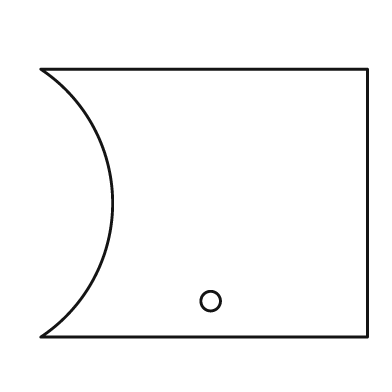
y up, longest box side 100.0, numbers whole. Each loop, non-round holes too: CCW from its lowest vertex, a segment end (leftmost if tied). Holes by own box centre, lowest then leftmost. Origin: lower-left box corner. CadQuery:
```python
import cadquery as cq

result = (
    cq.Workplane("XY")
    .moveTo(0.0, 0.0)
    .lineTo(100.0, 0.0)
    .lineTo(100.0, 82.0)
    .lineTo(0.0, 82.0)
    .threePointArc((22.0, 41.0), (0.0, 0.0))
    .close()
    .moveTo(52.0, 11.0)
    .circle(3.0)
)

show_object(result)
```